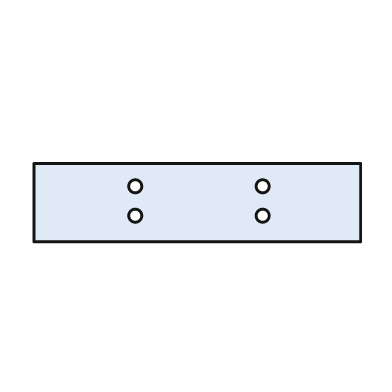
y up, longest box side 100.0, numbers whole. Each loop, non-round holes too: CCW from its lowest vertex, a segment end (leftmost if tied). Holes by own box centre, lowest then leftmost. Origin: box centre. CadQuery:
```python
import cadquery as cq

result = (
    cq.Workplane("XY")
    .moveTo(-50.0, -12.0)
    .lineTo(50.0, -12.0)
    .lineTo(50.0, 12.0)
    .lineTo(-50.0, 12.0)
    .close()
    .moveTo(-19.0, -4.0)
    .circle(2.0)
    .moveTo(20.0, -4.0)
    .circle(2.0)
    .moveTo(-19.0, 5.0)
    .circle(2.0)
    .moveTo(20.0, 5.0)
    .circle(2.0)
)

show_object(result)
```